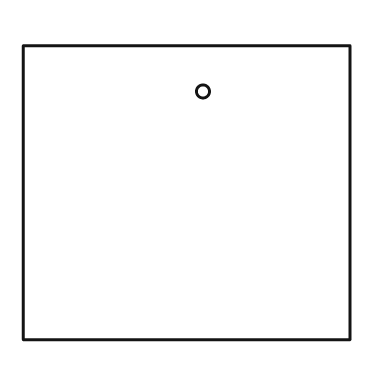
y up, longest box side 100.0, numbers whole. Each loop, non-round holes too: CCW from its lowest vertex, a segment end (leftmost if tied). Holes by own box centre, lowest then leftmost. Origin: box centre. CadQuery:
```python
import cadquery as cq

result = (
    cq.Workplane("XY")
    .moveTo(-50.0, -45.0)
    .lineTo(50.0, -45.0)
    .lineTo(50.0, 45.0)
    .lineTo(-50.0, 45.0)
    .close()
    .moveTo(5.0, 31.0)
    .circle(2.0)
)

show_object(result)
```